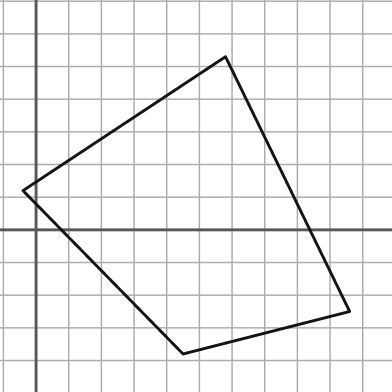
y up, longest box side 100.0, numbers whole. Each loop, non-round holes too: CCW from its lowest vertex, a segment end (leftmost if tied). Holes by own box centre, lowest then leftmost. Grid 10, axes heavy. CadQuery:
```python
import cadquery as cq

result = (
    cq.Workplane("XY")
    .moveTo(45.0, -38.0)
    .lineTo(96.0, -25.0)
    .lineTo(58.0, 53.0)
    .lineTo(-4.0, 12.0)
    .close()
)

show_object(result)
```